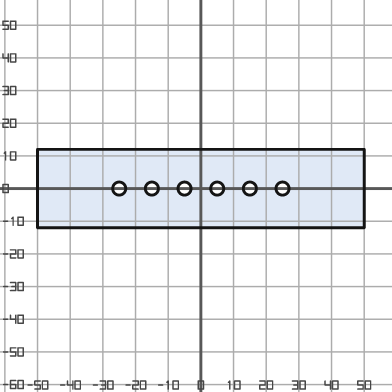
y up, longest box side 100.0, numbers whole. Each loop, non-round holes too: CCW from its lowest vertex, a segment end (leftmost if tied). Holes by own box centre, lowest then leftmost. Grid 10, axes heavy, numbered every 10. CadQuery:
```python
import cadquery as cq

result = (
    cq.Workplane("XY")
    .moveTo(-50.0, -12.0)
    .lineTo(50.0, -12.0)
    .lineTo(50.0, 12.0)
    .lineTo(-50.0, 12.0)
    .close()
    .moveTo(-25.0, 0.0)
    .circle(2.0)
    .moveTo(-15.0, 0.0)
    .circle(2.0)
    .moveTo(-5.0, 0.0)
    .circle(2.0)
    .moveTo(5.0, 0.0)
    .circle(2.0)
    .moveTo(15.0, 0.0)
    .circle(2.0)
    .moveTo(25.0, 0.0)
    .circle(2.0)
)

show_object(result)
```